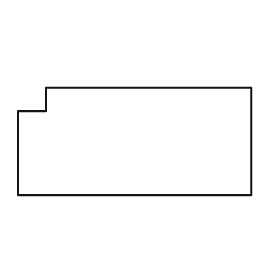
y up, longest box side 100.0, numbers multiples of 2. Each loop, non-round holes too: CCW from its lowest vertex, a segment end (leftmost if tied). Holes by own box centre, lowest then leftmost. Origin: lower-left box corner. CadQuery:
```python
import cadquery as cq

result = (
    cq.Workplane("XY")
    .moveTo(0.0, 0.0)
    .lineTo(100.0, 0.0)
    .lineTo(100.0, 46.0)
    .lineTo(12.0, 46.0)
    .lineTo(12.0, 36.0)
    .lineTo(0.0, 36.0)
    .close()
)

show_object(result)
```